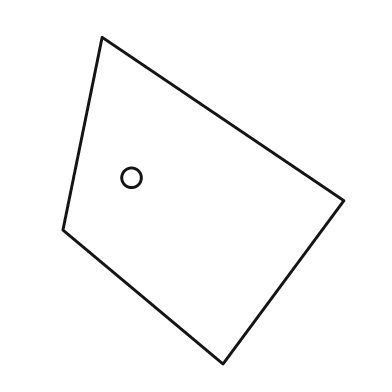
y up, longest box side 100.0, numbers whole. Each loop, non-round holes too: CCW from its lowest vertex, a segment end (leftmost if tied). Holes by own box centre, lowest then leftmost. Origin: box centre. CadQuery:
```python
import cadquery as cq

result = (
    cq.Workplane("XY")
    .moveTo(6.0, -50.0)
    .lineTo(43.0, 0.0)
    .lineTo(-31.0, 50.0)
    .lineTo(-43.0, -9.0)
    .close()
    .moveTo(-22.0, 7.0)
    .circle(3.0)
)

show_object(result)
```